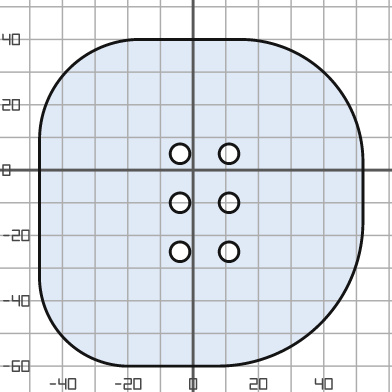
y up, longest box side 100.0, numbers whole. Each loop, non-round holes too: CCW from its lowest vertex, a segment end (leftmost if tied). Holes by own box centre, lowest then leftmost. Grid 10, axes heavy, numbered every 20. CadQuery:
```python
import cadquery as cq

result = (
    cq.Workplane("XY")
    .moveTo(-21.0, -60.0)
    .lineTo(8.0, -60.0)
    .threePointArc((39.0, -47.0), (52.0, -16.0))
    .lineTo(52.0, 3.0)
    .threePointArc((41.0, 29.0), (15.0, 40.0))
    .lineTo(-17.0, 40.0)
    .threePointArc((-38.0, 31.0), (-47.0, 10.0))
    .lineTo(-47.0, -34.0)
    .threePointArc((-39.0, -52.0), (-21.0, -60.0))
    .close()
    .moveTo(-4.0, -25.0)
    .circle(3.0)
    .moveTo(11.0, -25.0)
    .circle(3.0)
    .moveTo(-4.0, -10.0)
    .circle(3.0)
    .moveTo(11.0, -10.0)
    .circle(3.0)
    .moveTo(-4.0, 5.0)
    .circle(3.0)
    .moveTo(11.0, 5.0)
    .circle(3.0)
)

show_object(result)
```